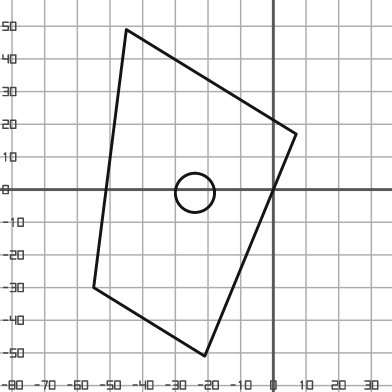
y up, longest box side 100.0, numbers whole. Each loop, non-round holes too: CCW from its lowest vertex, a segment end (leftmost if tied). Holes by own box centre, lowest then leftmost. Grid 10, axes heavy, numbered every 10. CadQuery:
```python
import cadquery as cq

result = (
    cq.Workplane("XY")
    .moveTo(-21.0, -51.0)
    .lineTo(7.0, 17.0)
    .lineTo(-45.0, 49.0)
    .lineTo(-55.0, -30.0)
    .close()
    .moveTo(-24.0, -1.0)
    .circle(6.0)
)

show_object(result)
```